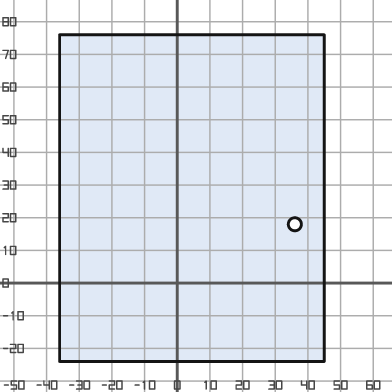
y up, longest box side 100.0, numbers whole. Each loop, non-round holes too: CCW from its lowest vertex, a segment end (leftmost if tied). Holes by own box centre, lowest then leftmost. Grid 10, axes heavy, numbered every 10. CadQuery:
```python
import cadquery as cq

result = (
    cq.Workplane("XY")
    .moveTo(-36.0, -24.0)
    .lineTo(45.0, -24.0)
    .lineTo(45.0, 76.0)
    .lineTo(-36.0, 76.0)
    .close()
    .moveTo(36.0, 18.0)
    .circle(2.0)
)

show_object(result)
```